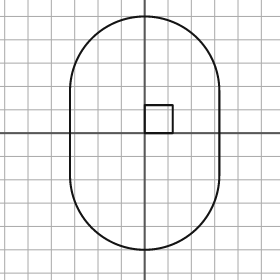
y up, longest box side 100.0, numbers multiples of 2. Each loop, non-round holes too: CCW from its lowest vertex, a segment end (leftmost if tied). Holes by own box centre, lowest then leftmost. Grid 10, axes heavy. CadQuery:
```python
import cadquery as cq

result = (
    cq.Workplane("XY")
    .moveTo(-32.0, -18.0)
    .threePointArc((0.0, -50.0), (32.0, -18.0))
    .lineTo(32.0, 18.0)
    .threePointArc((0.0, 50.0), (-32.0, 18.0))
    .close()
    .moveTo(0.0, 0.0)
    .lineTo(12.0, 0.0)
    .lineTo(12.0, 12.0)
    .lineTo(0.0, 12.0)
    .close()
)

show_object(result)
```